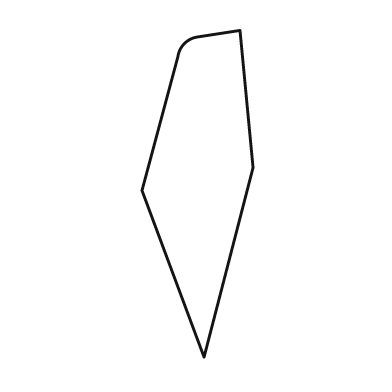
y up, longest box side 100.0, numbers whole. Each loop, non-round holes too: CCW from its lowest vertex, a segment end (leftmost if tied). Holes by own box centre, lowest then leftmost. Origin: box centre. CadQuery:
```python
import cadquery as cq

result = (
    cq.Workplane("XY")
    .moveTo(2.0, -50.0)
    .lineTo(17.0, 8.0)
    .lineTo(13.0, 50.0)
    .lineTo(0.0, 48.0)
    .threePointArc((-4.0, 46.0), (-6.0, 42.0))
    .lineTo(-17.0, 1.0)
    .close()
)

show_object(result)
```